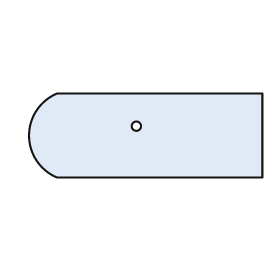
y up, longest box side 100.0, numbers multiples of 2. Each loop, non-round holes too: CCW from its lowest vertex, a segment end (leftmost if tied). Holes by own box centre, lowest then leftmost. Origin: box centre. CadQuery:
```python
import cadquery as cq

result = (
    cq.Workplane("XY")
    .moveTo(-38.0, -18.0)
    .lineTo(50.0, -18.0)
    .lineTo(50.0, 18.0)
    .lineTo(-38.0, 18.0)
    .threePointArc((-50.0, 0.0), (-38.0, -18.0))
    .close()
    .moveTo(-4.0, 4.0)
    .circle(2.0)
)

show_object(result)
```